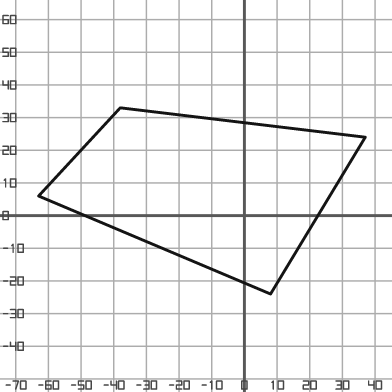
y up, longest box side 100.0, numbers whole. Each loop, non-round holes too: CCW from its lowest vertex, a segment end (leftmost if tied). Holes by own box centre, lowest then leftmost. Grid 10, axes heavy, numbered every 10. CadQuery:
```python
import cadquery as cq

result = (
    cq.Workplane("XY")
    .moveTo(8.0, -24.0)
    .lineTo(37.0, 24.0)
    .lineTo(-38.0, 33.0)
    .lineTo(-63.0, 6.0)
    .close()
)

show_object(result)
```